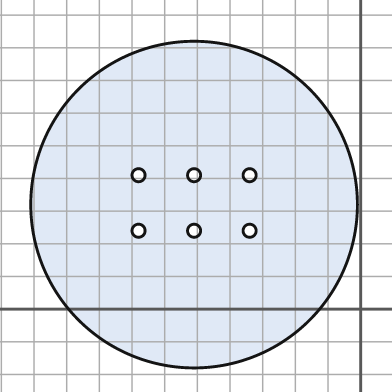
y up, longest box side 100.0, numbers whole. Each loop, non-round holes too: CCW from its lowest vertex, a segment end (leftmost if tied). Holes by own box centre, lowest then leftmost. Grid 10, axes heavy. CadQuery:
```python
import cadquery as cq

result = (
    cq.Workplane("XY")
    .moveTo(-51.0, 32.0)
    .circle(50.0)
    .moveTo(-68.0, 24.0)
    .circle(2.0)
    .moveTo(-51.0, 24.0)
    .circle(2.0)
    .moveTo(-34.0, 24.0)
    .circle(2.0)
    .moveTo(-68.0, 41.0)
    .circle(2.0)
    .moveTo(-51.0, 41.0)
    .circle(2.0)
    .moveTo(-34.0, 41.0)
    .circle(2.0)
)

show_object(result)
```